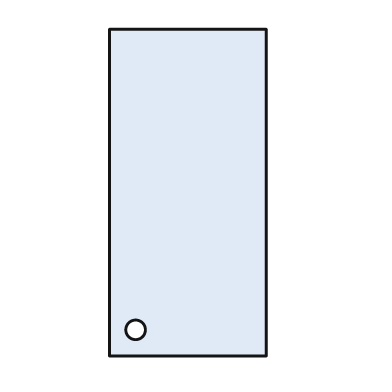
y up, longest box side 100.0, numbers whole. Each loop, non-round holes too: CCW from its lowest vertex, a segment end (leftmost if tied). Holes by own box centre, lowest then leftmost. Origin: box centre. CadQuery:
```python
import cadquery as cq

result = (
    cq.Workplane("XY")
    .moveTo(-24.0, -50.0)
    .lineTo(24.0, -50.0)
    .lineTo(24.0, 50.0)
    .lineTo(-24.0, 50.0)
    .close()
    .moveTo(-16.0, -42.0)
    .circle(3.0)
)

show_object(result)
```